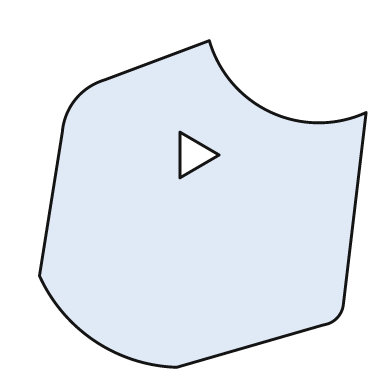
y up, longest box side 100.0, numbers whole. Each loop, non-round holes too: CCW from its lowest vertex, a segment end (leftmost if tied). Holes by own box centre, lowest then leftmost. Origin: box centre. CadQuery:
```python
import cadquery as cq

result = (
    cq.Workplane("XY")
    .moveTo(-8.0, -50.0)
    .lineTo(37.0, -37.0)
    .threePointArc((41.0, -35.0), (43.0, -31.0))
    .lineTo(50.0, 28.0)
    .threePointArc((21.0, 28.0), (2.0, 50.0))
    .lineTo(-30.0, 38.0)
    .threePointArc((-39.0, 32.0), (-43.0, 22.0))
    .lineTo(-50.0, -22.0)
    .threePointArc((-33.0, -42.0), (-8.0, -50.0))
    .close()
    .moveTo(-7.0, 8.0)
    .lineTo(5.0, 15.0)
    .lineTo(-7.0, 22.0)
    .close()
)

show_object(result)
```